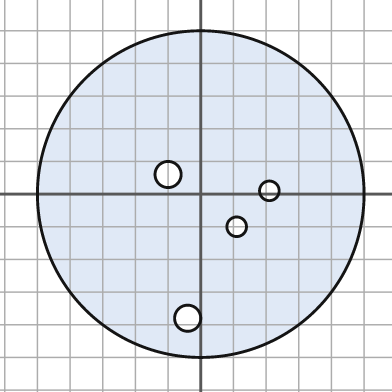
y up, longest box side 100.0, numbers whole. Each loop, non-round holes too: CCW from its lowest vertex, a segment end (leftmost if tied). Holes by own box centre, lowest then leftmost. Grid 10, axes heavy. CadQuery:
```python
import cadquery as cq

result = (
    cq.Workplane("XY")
    .moveTo(0.0, 0.0)
    .circle(50.0)
    .moveTo(-4.0, -38.0)
    .circle(4.0)
    .moveTo(11.0, -10.0)
    .circle(3.0)
    .moveTo(21.0, 1.0)
    .circle(3.0)
    .moveTo(-10.0, 6.0)
    .circle(4.0)
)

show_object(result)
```